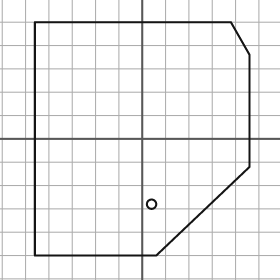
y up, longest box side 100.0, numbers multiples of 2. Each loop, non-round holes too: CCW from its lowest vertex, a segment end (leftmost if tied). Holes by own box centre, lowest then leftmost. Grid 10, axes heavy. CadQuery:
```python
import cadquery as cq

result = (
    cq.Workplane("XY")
    .moveTo(-46.0, -50.0)
    .lineTo(6.0, -50.0)
    .lineTo(46.0, -12.0)
    .lineTo(46.0, 36.0)
    .lineTo(38.0, 50.0)
    .lineTo(-46.0, 50.0)
    .close()
    .moveTo(4.0, -28.0)
    .circle(2.0)
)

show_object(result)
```